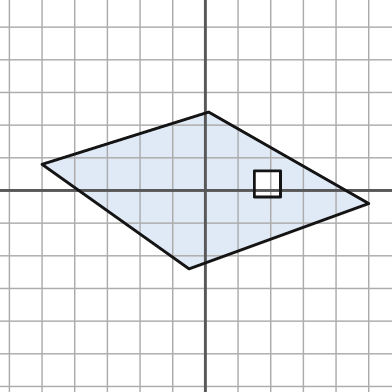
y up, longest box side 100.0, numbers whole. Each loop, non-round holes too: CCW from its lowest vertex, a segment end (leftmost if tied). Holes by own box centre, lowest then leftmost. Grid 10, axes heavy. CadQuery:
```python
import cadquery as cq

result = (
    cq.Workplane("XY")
    .moveTo(-5.0, -24.0)
    .lineTo(50.0, -4.0)
    .lineTo(1.0, 24.0)
    .lineTo(-50.0, 8.0)
    .close()
    .moveTo(15.0, -2.0)
    .lineTo(23.0, -2.0)
    .lineTo(23.0, 6.0)
    .lineTo(15.0, 6.0)
    .close()
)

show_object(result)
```